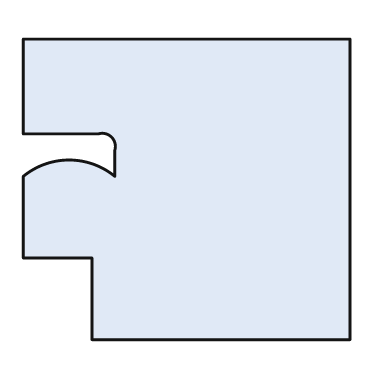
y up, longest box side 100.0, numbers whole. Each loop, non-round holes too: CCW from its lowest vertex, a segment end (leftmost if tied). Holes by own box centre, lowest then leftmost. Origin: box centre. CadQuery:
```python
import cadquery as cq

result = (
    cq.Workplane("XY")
    .moveTo(-29.0, -46.0)
    .lineTo(50.0, -46.0)
    .lineTo(50.0, 46.0)
    .lineTo(-50.0, 46.0)
    .lineTo(-50.0, 17.0)
    .lineTo(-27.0, 17.0)
    .threePointArc((-23.0, 16.0), (-22.0, 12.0))
    .lineTo(-22.0, 4.0)
    .threePointArc((-36.0, 9.0), (-50.0, 4.0))
    .lineTo(-50.0, -21.0)
    .lineTo(-29.0, -21.0)
    .close()
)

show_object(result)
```